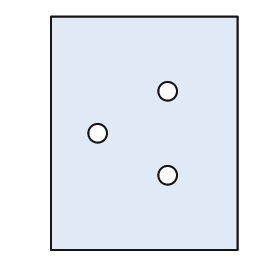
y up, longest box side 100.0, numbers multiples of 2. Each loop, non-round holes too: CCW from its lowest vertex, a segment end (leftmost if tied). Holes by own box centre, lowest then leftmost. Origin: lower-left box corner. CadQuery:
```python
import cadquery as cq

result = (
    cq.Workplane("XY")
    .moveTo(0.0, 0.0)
    .lineTo(80.0, 0.0)
    .lineTo(80.0, 100.0)
    .lineTo(0.0, 100.0)
    .close()
    .moveTo(50.0, 32.0)
    .circle(4.0)
    .moveTo(20.0, 50.0)
    .circle(4.0)
    .moveTo(50.0, 68.0)
    .circle(4.0)
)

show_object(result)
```